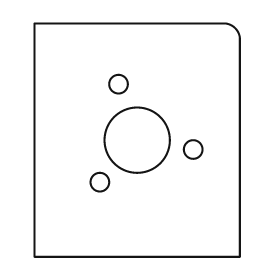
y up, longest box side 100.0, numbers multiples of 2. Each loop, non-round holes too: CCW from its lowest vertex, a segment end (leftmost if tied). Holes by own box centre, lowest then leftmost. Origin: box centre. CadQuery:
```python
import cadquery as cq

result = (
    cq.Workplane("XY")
    .moveTo(-44.0, -50.0)
    .lineTo(44.0, -50.0)
    .lineTo(44.0, 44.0)
    .threePointArc((42.0, 48.0), (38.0, 50.0))
    .lineTo(-44.0, 50.0)
    .close()
    .moveTo(-16.0, -18.0)
    .circle(4.0)
    .moveTo(24.0, -4.0)
    .circle(4.0)
    .moveTo(0.0, 0.0)
    .circle(14.0)
    .moveTo(-8.0, 24.0)
    .circle(4.0)
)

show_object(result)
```